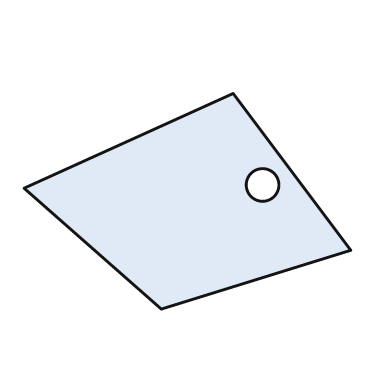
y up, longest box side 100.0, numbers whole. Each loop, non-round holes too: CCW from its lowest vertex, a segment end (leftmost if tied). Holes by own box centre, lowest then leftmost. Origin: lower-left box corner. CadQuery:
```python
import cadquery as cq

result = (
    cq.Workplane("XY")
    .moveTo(42.0, 0.0)
    .lineTo(100.0, 18.0)
    .lineTo(64.0, 66.0)
    .lineTo(0.0, 37.0)
    .close()
    .moveTo(73.0, 38.0)
    .circle(5.0)
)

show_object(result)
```